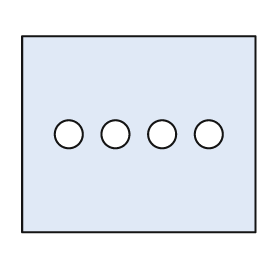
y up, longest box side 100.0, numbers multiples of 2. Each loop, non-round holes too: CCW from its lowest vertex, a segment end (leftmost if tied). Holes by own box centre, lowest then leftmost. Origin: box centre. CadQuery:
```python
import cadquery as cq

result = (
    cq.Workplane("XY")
    .moveTo(-50.0, -42.0)
    .lineTo(50.0, -42.0)
    .lineTo(50.0, 42.0)
    .lineTo(-50.0, 42.0)
    .close()
    .moveTo(-30.0, 0.0)
    .circle(6.0)
    .moveTo(-10.0, 0.0)
    .circle(6.0)
    .moveTo(10.0, 0.0)
    .circle(6.0)
    .moveTo(30.0, 0.0)
    .circle(6.0)
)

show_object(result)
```